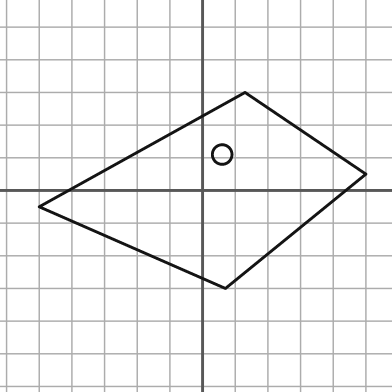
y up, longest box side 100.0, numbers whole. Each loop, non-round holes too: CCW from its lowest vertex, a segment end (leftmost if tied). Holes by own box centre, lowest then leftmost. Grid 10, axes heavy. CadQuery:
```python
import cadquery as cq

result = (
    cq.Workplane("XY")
    .moveTo(7.0, -30.0)
    .lineTo(50.0, 5.0)
    .lineTo(13.0, 30.0)
    .lineTo(-50.0, -5.0)
    .close()
    .moveTo(6.0, 11.0)
    .circle(3.0)
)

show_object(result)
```